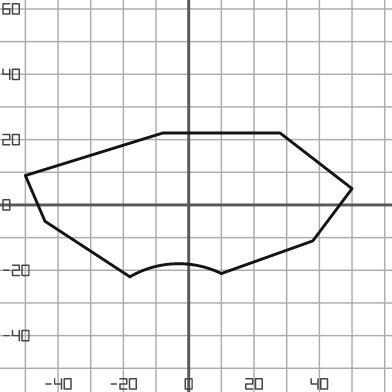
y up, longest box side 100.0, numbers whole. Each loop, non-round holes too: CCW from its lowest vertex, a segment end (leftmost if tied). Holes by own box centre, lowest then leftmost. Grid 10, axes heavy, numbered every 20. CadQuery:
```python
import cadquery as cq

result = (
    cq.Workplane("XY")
    .moveTo(-18.0, -22.0)
    .threePointArc((-4.0, -18.0), (10.0, -21.0))
    .lineTo(38.0, -11.0)
    .lineTo(50.0, 5.0)
    .lineTo(28.0, 22.0)
    .lineTo(-8.0, 22.0)
    .lineTo(-50.0, 9.0)
    .lineTo(-44.0, -5.0)
    .close()
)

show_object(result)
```